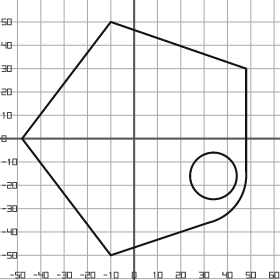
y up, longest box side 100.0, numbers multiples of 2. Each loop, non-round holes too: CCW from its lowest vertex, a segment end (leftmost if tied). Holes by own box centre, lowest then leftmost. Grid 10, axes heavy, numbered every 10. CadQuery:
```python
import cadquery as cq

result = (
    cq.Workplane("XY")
    .moveTo(-10.0, -50.0)
    .lineTo(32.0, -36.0)
    .threePointArc((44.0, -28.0), (48.0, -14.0))
    .lineTo(48.0, 30.0)
    .lineTo(-10.0, 50.0)
    .lineTo(-48.0, 0.0)
    .close()
    .moveTo(34.0, -16.0)
    .circle(10.0)
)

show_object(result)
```